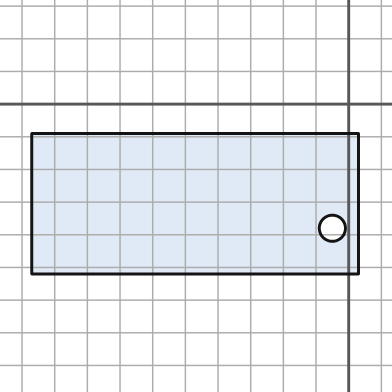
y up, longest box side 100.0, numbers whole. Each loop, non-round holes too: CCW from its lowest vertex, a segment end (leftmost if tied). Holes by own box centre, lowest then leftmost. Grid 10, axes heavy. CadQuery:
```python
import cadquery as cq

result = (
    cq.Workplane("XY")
    .moveTo(-97.0, -52.0)
    .lineTo(3.0, -52.0)
    .lineTo(3.0, -9.0)
    .lineTo(-97.0, -9.0)
    .close()
    .moveTo(-5.0, -38.0)
    .circle(4.0)
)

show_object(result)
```